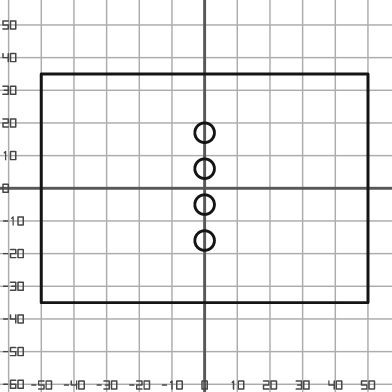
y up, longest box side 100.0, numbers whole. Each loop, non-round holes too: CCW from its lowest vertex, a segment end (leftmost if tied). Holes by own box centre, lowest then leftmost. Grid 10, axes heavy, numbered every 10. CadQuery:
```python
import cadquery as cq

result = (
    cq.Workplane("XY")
    .moveTo(-50.0, -35.0)
    .lineTo(50.0, -35.0)
    .lineTo(50.0, 35.0)
    .lineTo(-50.0, 35.0)
    .close()
    .moveTo(0.0, -16.0)
    .circle(3.0)
    .moveTo(0.0, -5.0)
    .circle(3.0)
    .moveTo(0.0, 6.0)
    .circle(3.0)
    .moveTo(0.0, 17.0)
    .circle(3.0)
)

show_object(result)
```